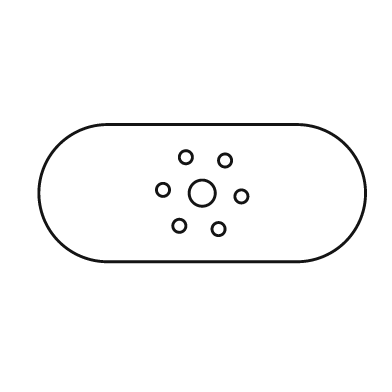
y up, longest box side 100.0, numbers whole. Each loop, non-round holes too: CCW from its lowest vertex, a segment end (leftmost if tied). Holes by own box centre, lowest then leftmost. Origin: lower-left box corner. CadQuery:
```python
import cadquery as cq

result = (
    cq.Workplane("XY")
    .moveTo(21.0, 0.0)
    .lineTo(79.0, 0.0)
    .threePointArc((100.0, 21.0), (79.0, 42.0))
    .lineTo(21.0, 42.0)
    .threePointArc((0.0, 21.0), (21.0, 0.0))
    .close()
    .moveTo(55.0, 10.0)
    .circle(2.0)
    .moveTo(43.0, 11.0)
    .circle(2.0)
    .moveTo(62.0, 20.0)
    .circle(2.0)
    .moveTo(50.0, 21.0)
    .circle(4.0)
    .moveTo(38.0, 22.0)
    .circle(2.0)
    .moveTo(57.0, 31.0)
    .circle(2.0)
    .moveTo(45.0, 32.0)
    .circle(2.0)
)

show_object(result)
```